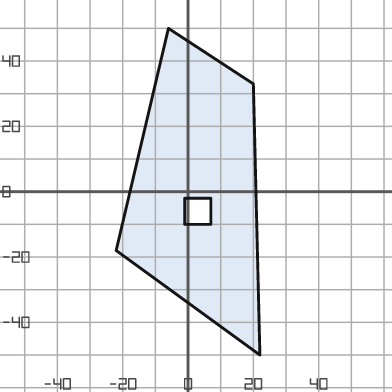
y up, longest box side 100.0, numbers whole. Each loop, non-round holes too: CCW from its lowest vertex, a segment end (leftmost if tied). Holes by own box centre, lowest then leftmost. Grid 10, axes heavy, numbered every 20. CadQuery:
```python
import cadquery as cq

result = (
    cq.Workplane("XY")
    .moveTo(22.0, -50.0)
    .lineTo(20.0, 33.0)
    .lineTo(-6.0, 50.0)
    .lineTo(-22.0, -18.0)
    .close()
    .moveTo(-1.0, -10.0)
    .lineTo(7.0, -10.0)
    .lineTo(7.0, -2.0)
    .lineTo(-1.0, -2.0)
    .close()
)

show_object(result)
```